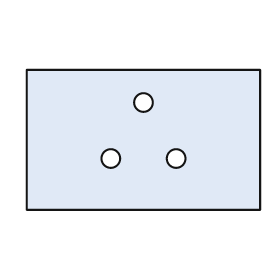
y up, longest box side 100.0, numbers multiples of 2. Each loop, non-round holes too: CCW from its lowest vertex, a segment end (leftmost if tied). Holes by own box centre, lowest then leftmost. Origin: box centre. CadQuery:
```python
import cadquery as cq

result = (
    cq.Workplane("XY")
    .moveTo(-50.0, -30.0)
    .lineTo(50.0, -30.0)
    .lineTo(50.0, 30.0)
    .lineTo(-50.0, 30.0)
    .close()
    .moveTo(-14.0, -8.0)
    .circle(4.0)
    .moveTo(14.0, -8.0)
    .circle(4.0)
    .moveTo(0.0, 16.0)
    .circle(4.0)
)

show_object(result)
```